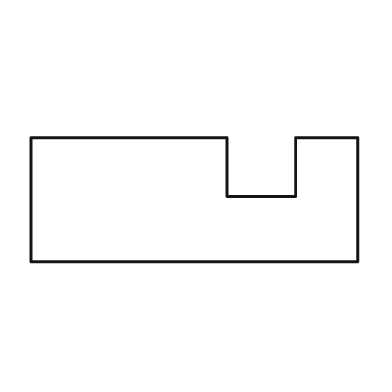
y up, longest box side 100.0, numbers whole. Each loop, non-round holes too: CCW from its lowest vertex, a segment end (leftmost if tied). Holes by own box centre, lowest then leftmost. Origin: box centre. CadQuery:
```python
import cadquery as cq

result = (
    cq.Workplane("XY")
    .moveTo(-50.0, -19.0)
    .lineTo(50.0, -19.0)
    .lineTo(50.0, 19.0)
    .lineTo(31.0, 19.0)
    .lineTo(31.0, 1.0)
    .lineTo(10.0, 1.0)
    .lineTo(10.0, 19.0)
    .lineTo(-50.0, 19.0)
    .close()
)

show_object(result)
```